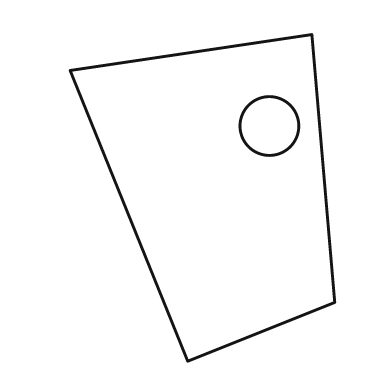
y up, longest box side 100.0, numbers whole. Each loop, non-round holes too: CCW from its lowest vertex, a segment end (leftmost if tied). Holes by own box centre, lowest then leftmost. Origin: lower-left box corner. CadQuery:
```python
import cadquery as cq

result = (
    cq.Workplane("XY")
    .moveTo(36.0, 0.0)
    .lineTo(81.0, 18.0)
    .lineTo(74.0, 100.0)
    .lineTo(0.0, 89.0)
    .close()
    .moveTo(61.0, 72.0)
    .circle(9.0)
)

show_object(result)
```